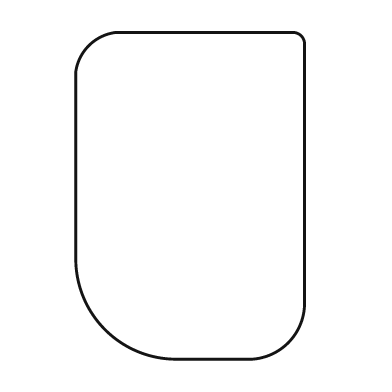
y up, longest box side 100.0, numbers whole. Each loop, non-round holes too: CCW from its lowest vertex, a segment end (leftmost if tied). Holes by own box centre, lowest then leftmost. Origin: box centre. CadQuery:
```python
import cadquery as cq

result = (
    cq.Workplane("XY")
    .moveTo(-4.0, -50.0)
    .lineTo(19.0, -50.0)
    .threePointArc((30.0, -45.0), (35.0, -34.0))
    .lineTo(35.0, 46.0)
    .threePointArc((34.0, 49.0), (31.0, 50.0))
    .lineTo(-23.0, 50.0)
    .threePointArc((-31.0, 46.0), (-35.0, 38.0))
    .lineTo(-35.0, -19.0)
    .threePointArc((-26.0, -41.0), (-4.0, -50.0))
    .close()
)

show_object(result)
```